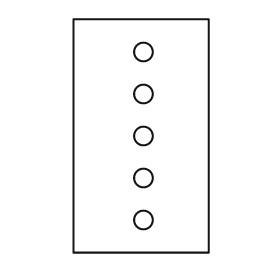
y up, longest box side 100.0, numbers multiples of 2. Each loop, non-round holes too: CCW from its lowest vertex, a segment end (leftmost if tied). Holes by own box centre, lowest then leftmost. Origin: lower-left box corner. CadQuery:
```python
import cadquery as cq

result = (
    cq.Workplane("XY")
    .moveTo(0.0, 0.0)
    .lineTo(58.0, 0.0)
    .lineTo(58.0, 100.0)
    .lineTo(0.0, 100.0)
    .close()
    .moveTo(30.0, 14.0)
    .circle(4.0)
    .moveTo(30.0, 32.0)
    .circle(4.0)
    .moveTo(30.0, 50.0)
    .circle(4.0)
    .moveTo(30.0, 68.0)
    .circle(4.0)
    .moveTo(30.0, 86.0)
    .circle(4.0)
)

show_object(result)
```